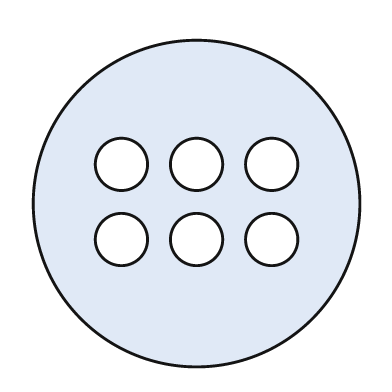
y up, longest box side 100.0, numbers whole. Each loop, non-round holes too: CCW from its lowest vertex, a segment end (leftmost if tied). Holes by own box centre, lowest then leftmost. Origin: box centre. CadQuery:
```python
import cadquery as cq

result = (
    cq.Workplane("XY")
    .moveTo(0.0, 0.0)
    .circle(50.0)
    .moveTo(-23.0, -11.0)
    .circle(8.0)
    .moveTo(0.0, -11.0)
    .circle(8.0)
    .moveTo(23.0, -11.0)
    .circle(8.0)
    .moveTo(-23.0, 12.0)
    .circle(8.0)
    .moveTo(0.0, 12.0)
    .circle(8.0)
    .moveTo(23.0, 12.0)
    .circle(8.0)
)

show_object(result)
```